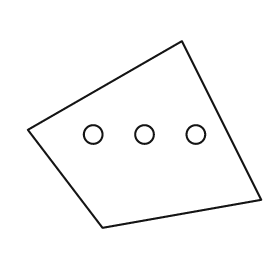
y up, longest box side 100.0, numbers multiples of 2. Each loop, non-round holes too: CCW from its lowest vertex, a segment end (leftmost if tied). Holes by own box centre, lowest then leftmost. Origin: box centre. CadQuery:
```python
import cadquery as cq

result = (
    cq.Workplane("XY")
    .moveTo(-18.0, -40.0)
    .lineTo(50.0, -28.0)
    .lineTo(16.0, 40.0)
    .lineTo(-50.0, 2.0)
    .close()
    .moveTo(-22.0, 0.0)
    .circle(4.0)
    .moveTo(0.0, 0.0)
    .circle(4.0)
    .moveTo(22.0, 0.0)
    .circle(4.0)
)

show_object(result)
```